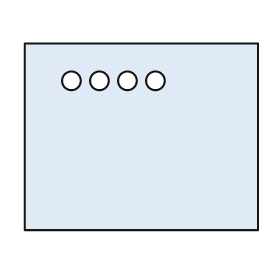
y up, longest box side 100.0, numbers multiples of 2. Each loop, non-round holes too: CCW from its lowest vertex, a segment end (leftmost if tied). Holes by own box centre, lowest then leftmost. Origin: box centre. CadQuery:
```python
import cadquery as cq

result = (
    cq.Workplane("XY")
    .moveTo(-50.0, -40.0)
    .lineTo(50.0, -40.0)
    .lineTo(50.0, 40.0)
    .lineTo(-50.0, 40.0)
    .close()
    .moveTo(-30.0, 24.0)
    .circle(4.0)
    .moveTo(-18.0, 24.0)
    .circle(4.0)
    .moveTo(-6.0, 24.0)
    .circle(4.0)
    .moveTo(6.0, 24.0)
    .circle(4.0)
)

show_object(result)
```